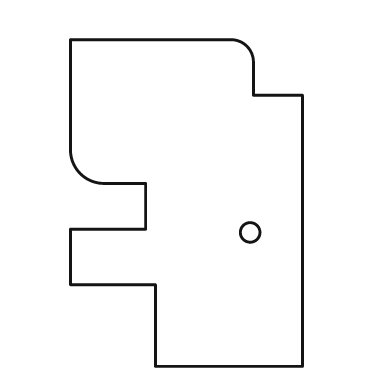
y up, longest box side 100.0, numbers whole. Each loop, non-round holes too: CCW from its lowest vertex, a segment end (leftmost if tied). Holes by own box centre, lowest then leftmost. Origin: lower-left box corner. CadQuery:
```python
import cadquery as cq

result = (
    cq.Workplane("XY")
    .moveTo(26.0, 0.0)
    .lineTo(71.0, 0.0)
    .lineTo(71.0, 83.0)
    .lineTo(56.0, 83.0)
    .lineTo(56.0, 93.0)
    .threePointArc((54.0, 98.0), (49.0, 100.0))
    .lineTo(0.0, 100.0)
    .lineTo(0.0, 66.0)
    .threePointArc((3.0, 59.0), (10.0, 56.0))
    .lineTo(23.0, 56.0)
    .lineTo(23.0, 42.0)
    .lineTo(0.0, 42.0)
    .lineTo(0.0, 25.0)
    .lineTo(26.0, 25.0)
    .close()
    .moveTo(55.0, 41.0)
    .circle(3.0)
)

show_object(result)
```